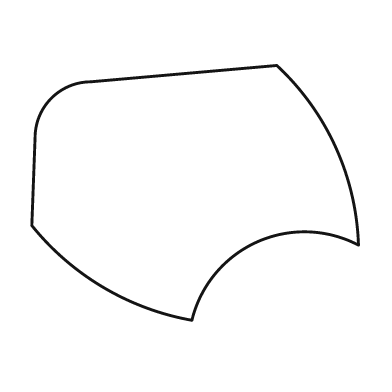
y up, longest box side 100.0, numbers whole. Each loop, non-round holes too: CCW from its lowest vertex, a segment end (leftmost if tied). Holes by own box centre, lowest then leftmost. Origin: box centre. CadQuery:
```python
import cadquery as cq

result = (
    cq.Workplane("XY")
    .moveTo(-1.0, -39.0)
    .threePointArc((19.0, -15.0), (50.0, -16.0))
    .threePointArc((43.0, 14.0), (25.0, 39.0))
    .lineTo(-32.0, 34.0)
    .threePointArc((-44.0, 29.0), (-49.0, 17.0))
    .lineTo(-50.0, -10.0)
    .threePointArc((-28.0, -29.0), (-1.0, -39.0))
    .close()
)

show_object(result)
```